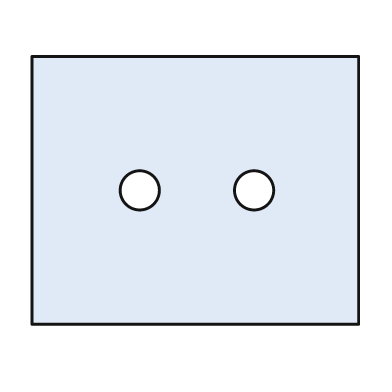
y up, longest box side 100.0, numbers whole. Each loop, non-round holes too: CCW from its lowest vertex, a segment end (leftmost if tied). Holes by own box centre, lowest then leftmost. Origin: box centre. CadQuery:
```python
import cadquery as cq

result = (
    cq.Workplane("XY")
    .moveTo(-50.0, -41.0)
    .lineTo(50.0, -41.0)
    .lineTo(50.0, 41.0)
    .lineTo(-50.0, 41.0)
    .close()
    .moveTo(-17.0, 0.0)
    .circle(6.0)
    .moveTo(18.0, 0.0)
    .circle(6.0)
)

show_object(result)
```